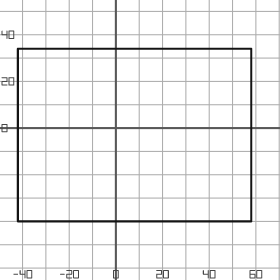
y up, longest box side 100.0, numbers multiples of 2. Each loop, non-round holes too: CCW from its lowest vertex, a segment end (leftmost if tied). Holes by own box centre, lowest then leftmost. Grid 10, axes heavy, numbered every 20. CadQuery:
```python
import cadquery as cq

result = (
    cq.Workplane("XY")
    .moveTo(-42.0, -40.0)
    .lineTo(58.0, -40.0)
    .lineTo(58.0, 34.0)
    .lineTo(-42.0, 34.0)
    .close()
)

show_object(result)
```